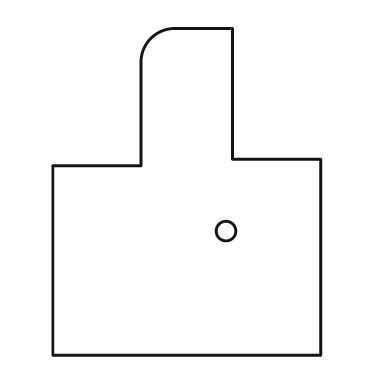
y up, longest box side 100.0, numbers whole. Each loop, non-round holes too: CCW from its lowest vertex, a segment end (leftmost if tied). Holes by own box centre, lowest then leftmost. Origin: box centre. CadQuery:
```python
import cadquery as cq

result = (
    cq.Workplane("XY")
    .moveTo(-41.0, -50.0)
    .lineTo(41.0, -50.0)
    .lineTo(41.0, 10.0)
    .lineTo(14.0, 10.0)
    .lineTo(14.0, 50.0)
    .lineTo(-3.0, 50.0)
    .threePointArc((-11.0, 47.0), (-14.0, 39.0))
    .lineTo(-14.0, 8.0)
    .lineTo(-41.0, 8.0)
    .close()
    .moveTo(12.0, -12.0)
    .circle(3.0)
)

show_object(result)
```